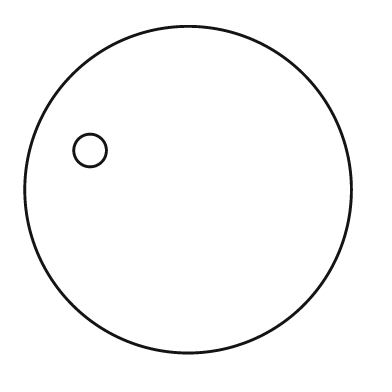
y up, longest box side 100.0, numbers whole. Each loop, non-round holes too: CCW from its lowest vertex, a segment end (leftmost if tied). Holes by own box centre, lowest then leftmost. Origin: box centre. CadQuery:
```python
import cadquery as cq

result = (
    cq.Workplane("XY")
    .moveTo(0.0, 0.0)
    .circle(50.0)
    .moveTo(-30.0, 12.0)
    .circle(5.0)
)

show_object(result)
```